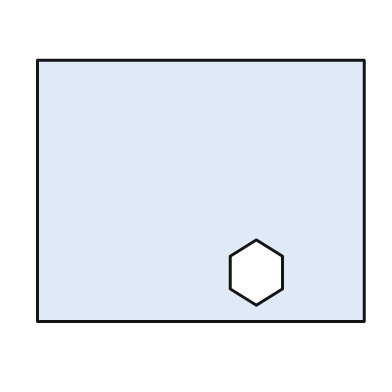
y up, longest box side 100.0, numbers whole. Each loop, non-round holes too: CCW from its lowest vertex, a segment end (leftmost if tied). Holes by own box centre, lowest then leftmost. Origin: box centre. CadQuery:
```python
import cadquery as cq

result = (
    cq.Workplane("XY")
    .moveTo(-50.0, -40.0)
    .lineTo(50.0, -40.0)
    .lineTo(50.0, 40.0)
    .lineTo(-50.0, 40.0)
    .close()
    .moveTo(17.0, -35.0)
    .lineTo(25.0, -30.0)
    .lineTo(25.0, -20.0)
    .lineTo(17.0, -15.0)
    .lineTo(9.0, -20.0)
    .lineTo(9.0, -30.0)
    .close()
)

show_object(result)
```